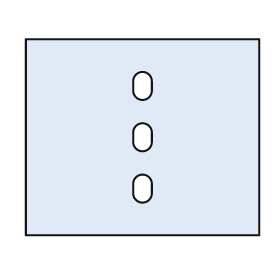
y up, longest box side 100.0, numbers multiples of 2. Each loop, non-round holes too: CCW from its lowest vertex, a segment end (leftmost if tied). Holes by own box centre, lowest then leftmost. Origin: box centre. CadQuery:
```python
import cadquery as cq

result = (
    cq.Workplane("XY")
    .moveTo(-50.0, -42.0)
    .lineTo(50.0, -42.0)
    .lineTo(50.0, 42.0)
    .lineTo(-50.0, 42.0)
    .close()
    .moveTo(-4.0, -24.0)
    .threePointArc((0.0, -28.0), (4.0, -24.0))
    .lineTo(4.0, -20.0)
    .threePointArc((0.0, -16.0), (-4.0, -20.0))
    .close()
    .moveTo(-4.0, -2.0)
    .threePointArc((0.0, -6.0), (4.0, -2.0))
    .lineTo(4.0, 2.0)
    .threePointArc((0.0, 6.0), (-4.0, 2.0))
    .close()
    .moveTo(-4.0, 20.0)
    .threePointArc((0.0, 16.0), (4.0, 20.0))
    .lineTo(4.0, 24.0)
    .threePointArc((0.0, 28.0), (-4.0, 24.0))
    .close()
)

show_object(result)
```